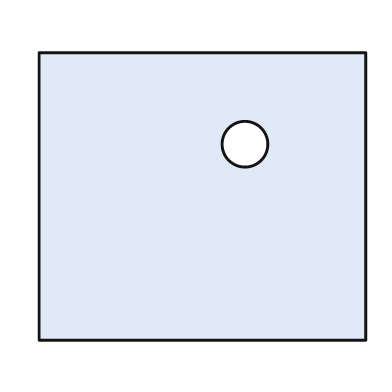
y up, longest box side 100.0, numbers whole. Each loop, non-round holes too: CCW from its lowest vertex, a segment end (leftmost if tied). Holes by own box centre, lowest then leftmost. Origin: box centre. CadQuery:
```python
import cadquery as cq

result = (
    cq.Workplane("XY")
    .moveTo(-50.0, -44.0)
    .lineTo(50.0, -44.0)
    .lineTo(50.0, 44.0)
    .lineTo(-50.0, 44.0)
    .close()
    .moveTo(13.0, 16.0)
    .circle(7.0)
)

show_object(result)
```